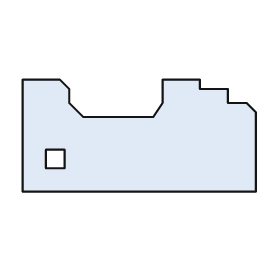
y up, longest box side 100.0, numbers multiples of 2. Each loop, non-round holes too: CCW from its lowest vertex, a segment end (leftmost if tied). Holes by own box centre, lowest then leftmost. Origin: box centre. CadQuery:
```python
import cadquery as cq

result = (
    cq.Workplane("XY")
    .moveTo(-50.0, -24.0)
    .lineTo(50.0, -24.0)
    .lineTo(50.0, 10.0)
    .lineTo(46.0, 14.0)
    .lineTo(38.0, 14.0)
    .lineTo(38.0, 20.0)
    .lineTo(26.0, 20.0)
    .lineTo(26.0, 24.0)
    .lineTo(10.0, 24.0)
    .lineTo(10.0, 14.0)
    .lineTo(6.0, 8.0)
    .lineTo(-24.0, 8.0)
    .lineTo(-30.0, 14.0)
    .lineTo(-30.0, 20.0)
    .lineTo(-34.0, 24.0)
    .lineTo(-50.0, 24.0)
    .close()
    .moveTo(-40.0, -14.0)
    .lineTo(-32.0, -14.0)
    .lineTo(-32.0, -6.0)
    .lineTo(-40.0, -6.0)
    .close()
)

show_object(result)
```